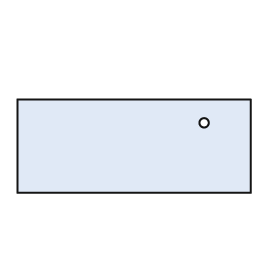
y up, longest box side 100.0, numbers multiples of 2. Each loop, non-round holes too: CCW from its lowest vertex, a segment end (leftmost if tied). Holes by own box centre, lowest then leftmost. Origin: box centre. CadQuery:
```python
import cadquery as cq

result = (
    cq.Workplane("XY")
    .moveTo(-50.0, -20.0)
    .lineTo(50.0, -20.0)
    .lineTo(50.0, 20.0)
    .lineTo(-50.0, 20.0)
    .close()
    .moveTo(30.0, 10.0)
    .circle(2.0)
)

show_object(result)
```